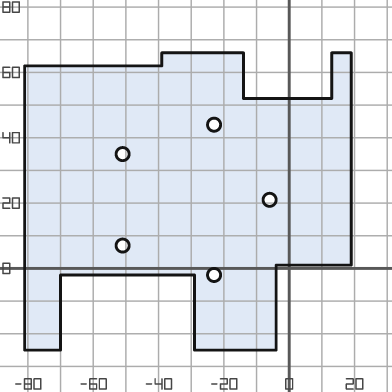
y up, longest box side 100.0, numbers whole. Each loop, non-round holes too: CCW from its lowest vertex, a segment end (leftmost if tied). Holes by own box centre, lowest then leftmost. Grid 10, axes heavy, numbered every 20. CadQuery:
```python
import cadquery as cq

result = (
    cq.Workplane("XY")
    .moveTo(-81.0, -25.0)
    .lineTo(-70.0, -25.0)
    .lineTo(-70.0, -2.0)
    .lineTo(-29.0, -2.0)
    .lineTo(-29.0, -25.0)
    .lineTo(-4.0, -25.0)
    .lineTo(-4.0, 1.0)
    .lineTo(19.0, 1.0)
    .lineTo(19.0, 66.0)
    .lineTo(13.0, 66.0)
    .lineTo(13.0, 52.0)
    .lineTo(-14.0, 52.0)
    .lineTo(-14.0, 66.0)
    .lineTo(-39.0, 66.0)
    .lineTo(-39.0, 62.0)
    .lineTo(-81.0, 62.0)
    .close()
    .moveTo(-23.0, -2.0)
    .circle(2.0)
    .moveTo(-51.0, 7.0)
    .circle(2.0)
    .moveTo(-6.0, 21.0)
    .circle(2.0)
    .moveTo(-51.0, 35.0)
    .circle(2.0)
    .moveTo(-23.0, 44.0)
    .circle(2.0)
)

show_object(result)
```